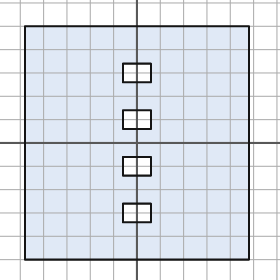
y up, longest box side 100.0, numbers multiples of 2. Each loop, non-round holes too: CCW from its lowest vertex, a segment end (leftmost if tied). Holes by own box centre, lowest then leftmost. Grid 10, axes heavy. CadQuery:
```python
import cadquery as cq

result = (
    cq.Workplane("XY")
    .moveTo(-48.0, -50.0)
    .lineTo(48.0, -50.0)
    .lineTo(48.0, 50.0)
    .lineTo(-48.0, 50.0)
    .close()
    .moveTo(-6.0, -34.0)
    .lineTo(6.0, -34.0)
    .lineTo(6.0, -26.0)
    .lineTo(-6.0, -26.0)
    .close()
    .moveTo(-6.0, -14.0)
    .lineTo(6.0, -14.0)
    .lineTo(6.0, -6.0)
    .lineTo(-6.0, -6.0)
    .close()
    .moveTo(-6.0, 6.0)
    .lineTo(6.0, 6.0)
    .lineTo(6.0, 14.0)
    .lineTo(-6.0, 14.0)
    .close()
    .moveTo(-6.0, 26.0)
    .lineTo(6.0, 26.0)
    .lineTo(6.0, 34.0)
    .lineTo(-6.0, 34.0)
    .close()
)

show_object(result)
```